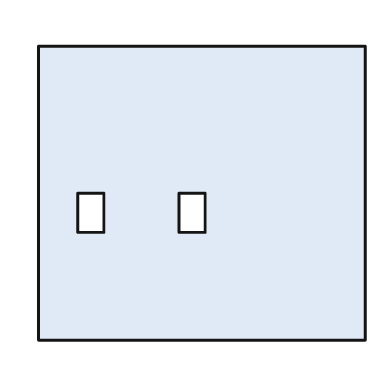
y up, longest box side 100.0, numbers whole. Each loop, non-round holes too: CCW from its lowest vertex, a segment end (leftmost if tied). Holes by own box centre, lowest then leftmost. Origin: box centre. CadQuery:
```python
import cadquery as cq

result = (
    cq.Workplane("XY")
    .moveTo(-50.0, -45.0)
    .lineTo(50.0, -45.0)
    .lineTo(50.0, 45.0)
    .lineTo(-50.0, 45.0)
    .close()
    .moveTo(-38.0, -12.0)
    .lineTo(-30.0, -12.0)
    .lineTo(-30.0, 0.0)
    .lineTo(-38.0, 0.0)
    .close()
    .moveTo(-7.0, -12.0)
    .lineTo(1.0, -12.0)
    .lineTo(1.0, 0.0)
    .lineTo(-7.0, 0.0)
    .close()
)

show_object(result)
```